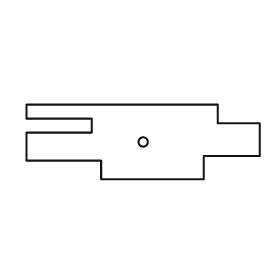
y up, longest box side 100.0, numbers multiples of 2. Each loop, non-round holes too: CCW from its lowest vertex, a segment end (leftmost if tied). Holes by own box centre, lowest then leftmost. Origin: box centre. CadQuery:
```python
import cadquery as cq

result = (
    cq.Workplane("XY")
    .moveTo(-18.0, -16.0)
    .lineTo(26.0, -16.0)
    .lineTo(26.0, -6.0)
    .lineTo(50.0, -6.0)
    .lineTo(50.0, 8.0)
    .lineTo(32.0, 8.0)
    .lineTo(32.0, 16.0)
    .lineTo(-50.0, 16.0)
    .lineTo(-50.0, 10.0)
    .lineTo(-22.0, 10.0)
    .lineTo(-22.0, 4.0)
    .lineTo(-50.0, 4.0)
    .lineTo(-50.0, -8.0)
    .lineTo(-18.0, -8.0)
    .close()
    .moveTo(0.0, 0.0)
    .circle(2.0)
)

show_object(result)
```